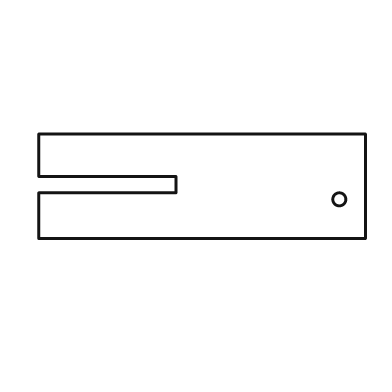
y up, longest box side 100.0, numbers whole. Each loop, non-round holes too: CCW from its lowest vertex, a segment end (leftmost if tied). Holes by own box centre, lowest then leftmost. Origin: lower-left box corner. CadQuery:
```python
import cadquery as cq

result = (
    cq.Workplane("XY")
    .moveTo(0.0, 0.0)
    .lineTo(100.0, 0.0)
    .lineTo(100.0, 32.0)
    .lineTo(0.0, 32.0)
    .lineTo(0.0, 19.0)
    .lineTo(42.0, 19.0)
    .lineTo(42.0, 14.0)
    .lineTo(0.0, 14.0)
    .close()
    .moveTo(92.0, 12.0)
    .circle(2.0)
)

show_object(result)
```